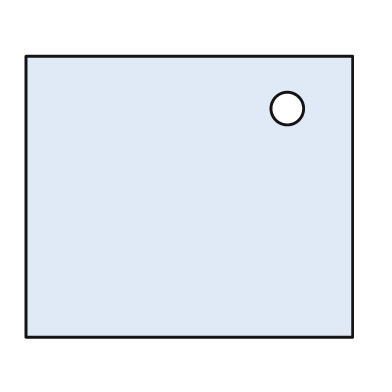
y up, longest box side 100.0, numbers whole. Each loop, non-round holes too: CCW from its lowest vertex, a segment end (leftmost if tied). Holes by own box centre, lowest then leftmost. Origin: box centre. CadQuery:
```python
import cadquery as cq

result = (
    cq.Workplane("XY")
    .moveTo(-50.0, -43.0)
    .lineTo(50.0, -43.0)
    .lineTo(50.0, 43.0)
    .lineTo(-50.0, 43.0)
    .close()
    .moveTo(30.0, 27.0)
    .circle(5.0)
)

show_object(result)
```